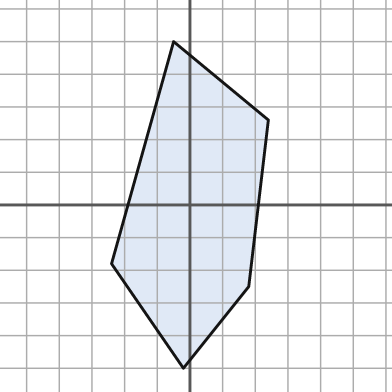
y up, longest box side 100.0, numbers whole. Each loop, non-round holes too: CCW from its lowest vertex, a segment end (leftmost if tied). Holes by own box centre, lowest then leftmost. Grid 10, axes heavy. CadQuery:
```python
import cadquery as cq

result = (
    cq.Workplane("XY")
    .moveTo(-2.0, -50.0)
    .lineTo(18.0, -25.0)
    .lineTo(24.0, 26.0)
    .lineTo(-5.0, 50.0)
    .lineTo(-24.0, -18.0)
    .close()
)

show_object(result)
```